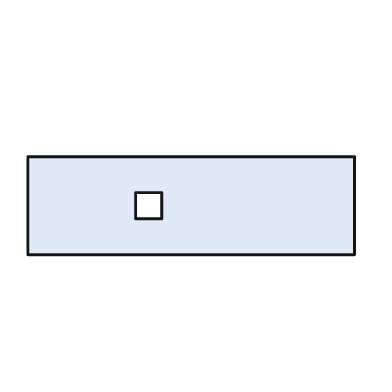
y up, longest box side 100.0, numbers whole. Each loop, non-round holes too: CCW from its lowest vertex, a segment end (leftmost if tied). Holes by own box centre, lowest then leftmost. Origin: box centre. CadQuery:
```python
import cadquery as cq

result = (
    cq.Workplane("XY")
    .moveTo(-50.0, -15.0)
    .lineTo(50.0, -15.0)
    .lineTo(50.0, 15.0)
    .lineTo(-50.0, 15.0)
    .close()
    .moveTo(-17.0, -4.0)
    .lineTo(-9.0, -4.0)
    .lineTo(-9.0, 4.0)
    .lineTo(-17.0, 4.0)
    .close()
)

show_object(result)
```